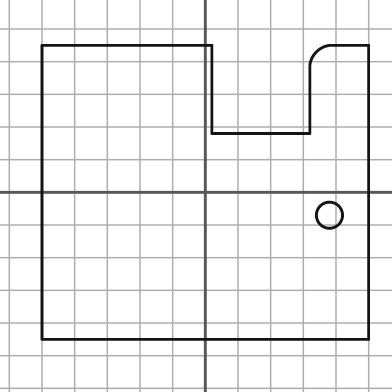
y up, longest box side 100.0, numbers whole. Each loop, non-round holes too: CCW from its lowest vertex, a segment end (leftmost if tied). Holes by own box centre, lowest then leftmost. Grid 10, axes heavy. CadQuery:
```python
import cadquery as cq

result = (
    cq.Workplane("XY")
    .moveTo(-50.0, -45.0)
    .lineTo(50.0, -45.0)
    .lineTo(50.0, 45.0)
    .lineTo(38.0, 45.0)
    .threePointArc((34.0, 43.0), (32.0, 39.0))
    .lineTo(32.0, 18.0)
    .lineTo(2.0, 18.0)
    .lineTo(2.0, 45.0)
    .lineTo(-50.0, 45.0)
    .close()
    .moveTo(38.0, -7.0)
    .circle(4.0)
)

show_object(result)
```